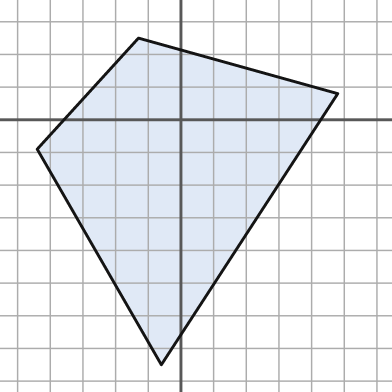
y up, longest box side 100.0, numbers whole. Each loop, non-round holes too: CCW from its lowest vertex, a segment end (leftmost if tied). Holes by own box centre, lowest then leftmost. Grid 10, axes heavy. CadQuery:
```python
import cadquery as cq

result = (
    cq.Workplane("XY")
    .moveTo(-6.0, -75.0)
    .lineTo(48.0, 8.0)
    .lineTo(-13.0, 25.0)
    .lineTo(-44.0, -9.0)
    .close()
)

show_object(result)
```